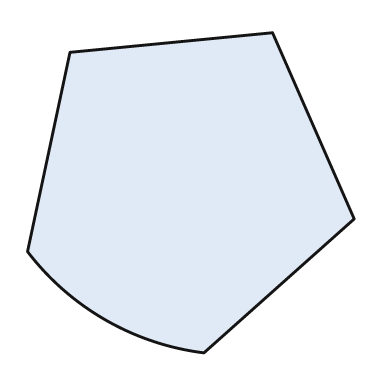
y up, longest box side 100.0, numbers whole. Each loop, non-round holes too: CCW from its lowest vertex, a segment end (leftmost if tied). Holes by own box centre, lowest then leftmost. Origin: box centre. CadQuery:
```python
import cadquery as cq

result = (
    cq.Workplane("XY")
    .moveTo(4.0, -49.0)
    .lineTo(50.0, -8.0)
    .lineTo(25.0, 49.0)
    .lineTo(-37.0, 43.0)
    .lineTo(-50.0, -18.0)
    .threePointArc((-26.0, -39.0), (4.0, -49.0))
    .close()
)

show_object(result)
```